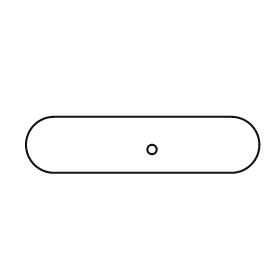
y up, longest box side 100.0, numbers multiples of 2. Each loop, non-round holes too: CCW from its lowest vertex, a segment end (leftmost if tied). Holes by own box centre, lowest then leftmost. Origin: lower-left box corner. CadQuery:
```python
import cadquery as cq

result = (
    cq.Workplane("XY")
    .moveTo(12.0, 0.0)
    .lineTo(88.0, 0.0)
    .threePointArc((100.0, 12.0), (88.0, 24.0))
    .lineTo(12.0, 24.0)
    .threePointArc((0.0, 12.0), (12.0, 0.0))
    .close()
    .moveTo(54.0, 10.0)
    .circle(2.0)
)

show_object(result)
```